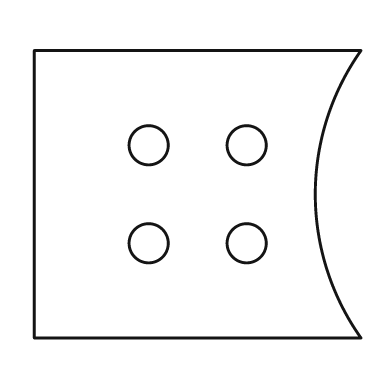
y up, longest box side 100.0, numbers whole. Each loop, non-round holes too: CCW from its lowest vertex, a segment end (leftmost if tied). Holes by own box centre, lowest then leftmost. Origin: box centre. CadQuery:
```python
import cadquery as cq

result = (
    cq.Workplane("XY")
    .moveTo(-50.0, -44.0)
    .lineTo(50.0, -44.0)
    .threePointArc((36.0, 0.0), (50.0, 44.0))
    .lineTo(-50.0, 44.0)
    .close()
    .moveTo(-15.0, -15.0)
    .circle(6.0)
    .moveTo(15.0, -15.0)
    .circle(6.0)
    .moveTo(-15.0, 15.0)
    .circle(6.0)
    .moveTo(15.0, 15.0)
    .circle(6.0)
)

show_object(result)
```